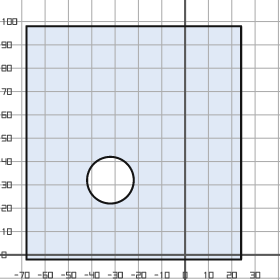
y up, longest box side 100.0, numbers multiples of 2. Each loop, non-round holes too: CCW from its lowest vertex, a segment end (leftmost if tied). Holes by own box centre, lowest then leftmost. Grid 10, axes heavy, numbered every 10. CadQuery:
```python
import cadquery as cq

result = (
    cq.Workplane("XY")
    .moveTo(-68.0, -2.0)
    .lineTo(24.0, -2.0)
    .lineTo(24.0, 98.0)
    .lineTo(-68.0, 98.0)
    .close()
    .moveTo(-32.0, 32.0)
    .circle(10.0)
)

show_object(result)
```